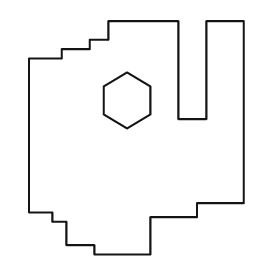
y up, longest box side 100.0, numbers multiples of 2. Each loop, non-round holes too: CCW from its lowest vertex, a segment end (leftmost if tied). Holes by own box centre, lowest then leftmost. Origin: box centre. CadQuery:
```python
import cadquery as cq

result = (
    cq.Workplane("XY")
    .moveTo(-18.0, -50.0)
    .lineTo(6.0, -50.0)
    .lineTo(6.0, -34.0)
    .lineTo(26.0, -34.0)
    .lineTo(26.0, -28.0)
    .lineTo(46.0, -28.0)
    .lineTo(46.0, 50.0)
    .lineTo(30.0, 50.0)
    .lineTo(30.0, 8.0)
    .lineTo(18.0, 8.0)
    .lineTo(18.0, 50.0)
    .lineTo(-12.0, 50.0)
    .lineTo(-12.0, 42.0)
    .lineTo(-20.0, 42.0)
    .lineTo(-20.0, 38.0)
    .lineTo(-32.0, 38.0)
    .lineTo(-32.0, 34.0)
    .lineTo(-46.0, 34.0)
    .lineTo(-46.0, -32.0)
    .lineTo(-36.0, -32.0)
    .lineTo(-36.0, -36.0)
    .lineTo(-30.0, -36.0)
    .lineTo(-30.0, -46.0)
    .lineTo(-18.0, -46.0)
    .close()
    .moveTo(-4.0, 4.0)
    .lineTo(6.0, 10.0)
    .lineTo(6.0, 22.0)
    .lineTo(-4.0, 28.0)
    .lineTo(-14.0, 22.0)
    .lineTo(-14.0, 10.0)
    .close()
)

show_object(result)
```